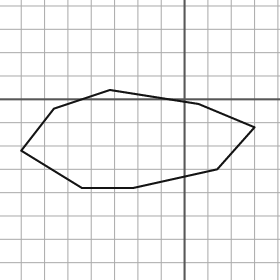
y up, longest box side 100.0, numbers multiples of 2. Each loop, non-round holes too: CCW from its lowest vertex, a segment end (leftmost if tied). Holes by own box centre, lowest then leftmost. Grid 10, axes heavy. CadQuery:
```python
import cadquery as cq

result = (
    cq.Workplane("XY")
    .moveTo(-44.0, -38.0)
    .lineTo(-22.0, -38.0)
    .lineTo(14.0, -30.0)
    .lineTo(30.0, -12.0)
    .lineTo(6.0, -2.0)
    .lineTo(-32.0, 4.0)
    .lineTo(-56.0, -4.0)
    .lineTo(-70.0, -22.0)
    .close()
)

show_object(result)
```